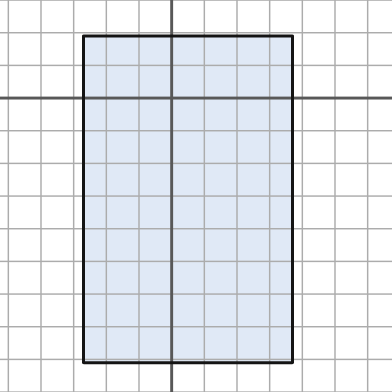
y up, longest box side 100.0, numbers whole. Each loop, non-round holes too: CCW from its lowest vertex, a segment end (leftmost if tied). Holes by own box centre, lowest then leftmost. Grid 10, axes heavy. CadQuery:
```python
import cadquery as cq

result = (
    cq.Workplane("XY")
    .moveTo(-27.0, -81.0)
    .lineTo(37.0, -81.0)
    .lineTo(37.0, 19.0)
    .lineTo(-27.0, 19.0)
    .close()
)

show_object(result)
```